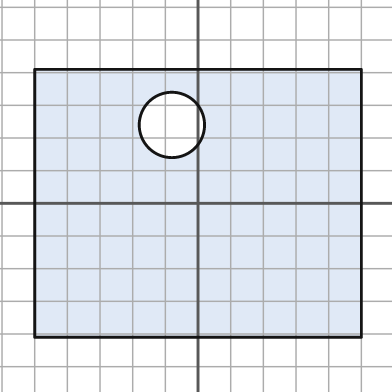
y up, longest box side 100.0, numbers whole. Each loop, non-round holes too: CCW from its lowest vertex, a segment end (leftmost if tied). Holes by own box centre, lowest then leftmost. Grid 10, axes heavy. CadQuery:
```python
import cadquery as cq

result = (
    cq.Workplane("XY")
    .moveTo(-50.0, -41.0)
    .lineTo(50.0, -41.0)
    .lineTo(50.0, 41.0)
    .lineTo(-50.0, 41.0)
    .close()
    .moveTo(-8.0, 24.0)
    .circle(10.0)
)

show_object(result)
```